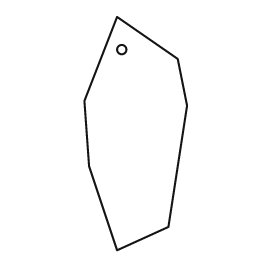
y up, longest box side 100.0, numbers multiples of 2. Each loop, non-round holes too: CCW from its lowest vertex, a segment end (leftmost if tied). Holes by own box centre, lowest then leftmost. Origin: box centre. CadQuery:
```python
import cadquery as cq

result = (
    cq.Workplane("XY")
    .moveTo(-8.0, -50.0)
    .lineTo(14.0, -40.0)
    .lineTo(22.0, 12.0)
    .lineTo(18.0, 32.0)
    .lineTo(-8.0, 50.0)
    .lineTo(-22.0, 14.0)
    .lineTo(-20.0, -14.0)
    .close()
    .moveTo(-6.0, 36.0)
    .circle(2.0)
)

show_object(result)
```